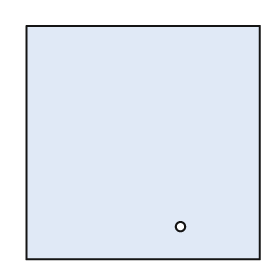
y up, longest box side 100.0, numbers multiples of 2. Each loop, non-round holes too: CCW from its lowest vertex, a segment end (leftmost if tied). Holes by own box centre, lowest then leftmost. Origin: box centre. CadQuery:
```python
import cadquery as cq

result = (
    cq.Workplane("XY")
    .moveTo(-50.0, -50.0)
    .lineTo(50.0, -50.0)
    .lineTo(50.0, 50.0)
    .lineTo(-50.0, 50.0)
    .close()
    .moveTo(16.0, -36.0)
    .circle(2.0)
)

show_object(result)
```